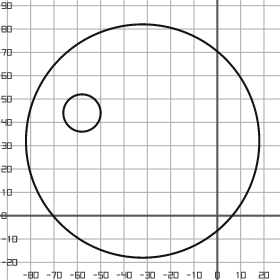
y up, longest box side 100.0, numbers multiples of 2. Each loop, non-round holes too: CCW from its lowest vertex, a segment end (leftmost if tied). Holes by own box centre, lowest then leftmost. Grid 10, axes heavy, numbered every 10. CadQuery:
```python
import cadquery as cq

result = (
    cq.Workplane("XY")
    .moveTo(-32.0, 32.0)
    .circle(50.0)
    .moveTo(-58.0, 44.0)
    .circle(8.0)
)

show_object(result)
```